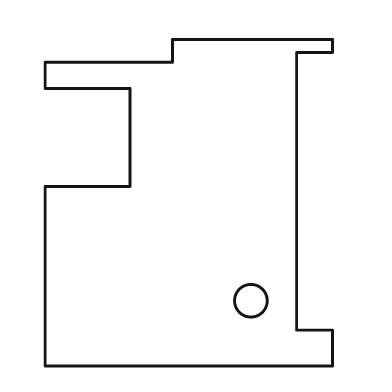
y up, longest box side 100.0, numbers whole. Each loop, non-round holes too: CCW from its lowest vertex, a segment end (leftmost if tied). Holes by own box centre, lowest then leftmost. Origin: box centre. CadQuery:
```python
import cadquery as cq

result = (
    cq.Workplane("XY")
    .moveTo(-44.0, -50.0)
    .lineTo(44.0, -50.0)
    .lineTo(44.0, -39.0)
    .lineTo(33.0, -39.0)
    .lineTo(33.0, 46.0)
    .lineTo(44.0, 46.0)
    .lineTo(44.0, 50.0)
    .lineTo(-5.0, 50.0)
    .lineTo(-5.0, 43.0)
    .lineTo(-44.0, 43.0)
    .lineTo(-44.0, 35.0)
    .lineTo(-18.0, 35.0)
    .lineTo(-18.0, 5.0)
    .lineTo(-44.0, 5.0)
    .close()
    .moveTo(19.0, -30.0)
    .circle(5.0)
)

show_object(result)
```